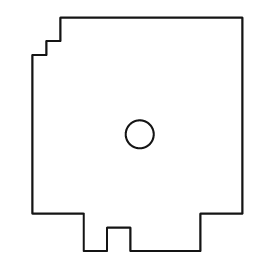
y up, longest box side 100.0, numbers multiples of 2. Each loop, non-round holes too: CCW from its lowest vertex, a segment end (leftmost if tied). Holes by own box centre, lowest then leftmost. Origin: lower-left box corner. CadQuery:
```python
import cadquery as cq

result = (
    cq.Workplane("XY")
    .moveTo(22.0, 0.0)
    .lineTo(32.0, 0.0)
    .lineTo(32.0, 10.0)
    .lineTo(42.0, 10.0)
    .lineTo(42.0, 0.0)
    .lineTo(72.0, 0.0)
    .lineTo(72.0, 16.0)
    .lineTo(90.0, 16.0)
    .lineTo(90.0, 100.0)
    .lineTo(12.0, 100.0)
    .lineTo(12.0, 90.0)
    .lineTo(6.0, 90.0)
    .lineTo(6.0, 84.0)
    .lineTo(0.0, 84.0)
    .lineTo(0.0, 16.0)
    .lineTo(22.0, 16.0)
    .close()
    .moveTo(46.0, 50.0)
    .circle(6.0)
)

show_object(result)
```